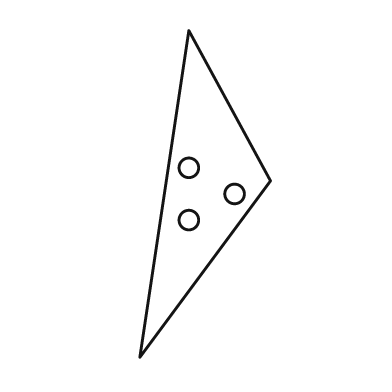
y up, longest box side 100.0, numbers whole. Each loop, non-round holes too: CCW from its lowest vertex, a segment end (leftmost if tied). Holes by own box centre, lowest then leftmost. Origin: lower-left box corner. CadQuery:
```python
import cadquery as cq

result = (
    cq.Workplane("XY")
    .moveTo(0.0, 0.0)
    .lineTo(40.0, 54.0)
    .lineTo(15.0, 100.0)
    .close()
    .moveTo(15.0, 42.0)
    .circle(3.0)
    .moveTo(29.0, 50.0)
    .circle(3.0)
    .moveTo(15.0, 58.0)
    .circle(3.0)
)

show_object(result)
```